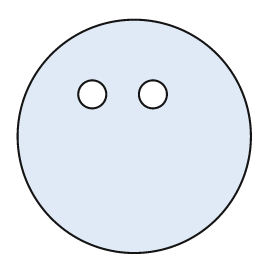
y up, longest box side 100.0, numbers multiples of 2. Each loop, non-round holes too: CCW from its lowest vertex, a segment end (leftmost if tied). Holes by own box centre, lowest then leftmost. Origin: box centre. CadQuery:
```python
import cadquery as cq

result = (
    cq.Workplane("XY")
    .moveTo(0.0, 0.0)
    .circle(50.0)
    .moveTo(-18.0, 18.0)
    .circle(6.0)
    .moveTo(8.0, 18.0)
    .circle(6.0)
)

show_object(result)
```